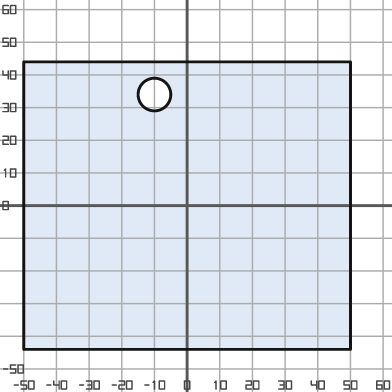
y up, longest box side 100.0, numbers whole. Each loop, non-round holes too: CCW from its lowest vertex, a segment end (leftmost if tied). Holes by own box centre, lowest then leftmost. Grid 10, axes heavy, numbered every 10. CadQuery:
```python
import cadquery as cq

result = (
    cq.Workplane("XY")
    .moveTo(-50.0, -44.0)
    .lineTo(50.0, -44.0)
    .lineTo(50.0, 44.0)
    .lineTo(-50.0, 44.0)
    .close()
    .moveTo(-10.0, 34.0)
    .circle(5.0)
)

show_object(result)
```